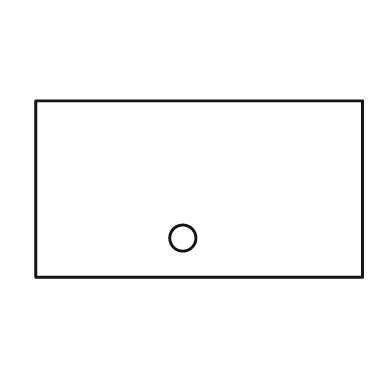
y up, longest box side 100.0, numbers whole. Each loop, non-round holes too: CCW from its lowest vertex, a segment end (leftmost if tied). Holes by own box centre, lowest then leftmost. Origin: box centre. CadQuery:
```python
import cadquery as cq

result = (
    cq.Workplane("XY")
    .moveTo(-50.0, -27.0)
    .lineTo(50.0, -27.0)
    .lineTo(50.0, 27.0)
    .lineTo(-50.0, 27.0)
    .close()
    .moveTo(-5.0, -15.0)
    .circle(4.0)
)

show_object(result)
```